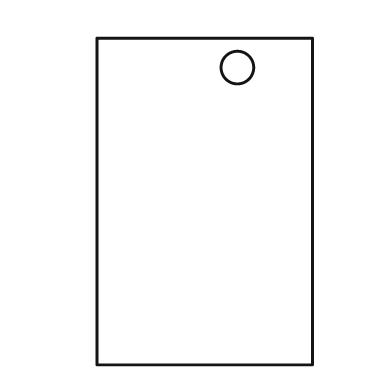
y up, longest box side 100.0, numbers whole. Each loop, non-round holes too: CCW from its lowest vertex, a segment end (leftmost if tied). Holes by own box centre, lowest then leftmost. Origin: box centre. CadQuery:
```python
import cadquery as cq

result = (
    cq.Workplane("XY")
    .moveTo(-33.0, -50.0)
    .lineTo(33.0, -50.0)
    .lineTo(33.0, 50.0)
    .lineTo(-33.0, 50.0)
    .close()
    .moveTo(10.0, 41.0)
    .circle(5.0)
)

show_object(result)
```